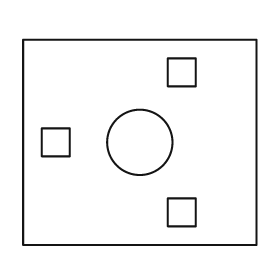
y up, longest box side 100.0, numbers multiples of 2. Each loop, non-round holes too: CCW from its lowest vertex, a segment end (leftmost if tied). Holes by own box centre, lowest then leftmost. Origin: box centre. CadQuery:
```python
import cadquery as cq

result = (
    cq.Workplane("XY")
    .moveTo(-50.0, -44.0)
    .lineTo(50.0, -44.0)
    .lineTo(50.0, 44.0)
    .lineTo(-50.0, 44.0)
    .close()
    .moveTo(12.0, -36.0)
    .lineTo(24.0, -36.0)
    .lineTo(24.0, -24.0)
    .lineTo(12.0, -24.0)
    .close()
    .moveTo(-42.0, -6.0)
    .lineTo(-30.0, -6.0)
    .lineTo(-30.0, 6.0)
    .lineTo(-42.0, 6.0)
    .close()
    .moveTo(0.0, 0.0)
    .circle(14.0)
    .moveTo(12.0, 24.0)
    .lineTo(24.0, 24.0)
    .lineTo(24.0, 36.0)
    .lineTo(12.0, 36.0)
    .close()
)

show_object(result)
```